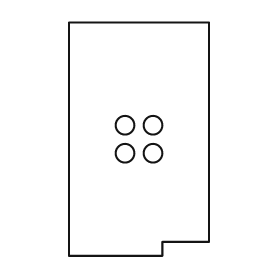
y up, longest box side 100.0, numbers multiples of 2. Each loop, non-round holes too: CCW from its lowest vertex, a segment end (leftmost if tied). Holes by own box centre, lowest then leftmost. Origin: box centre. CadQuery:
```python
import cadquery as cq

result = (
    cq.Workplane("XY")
    .moveTo(-30.0, -50.0)
    .lineTo(10.0, -50.0)
    .lineTo(10.0, -44.0)
    .lineTo(30.0, -44.0)
    .lineTo(30.0, 50.0)
    .lineTo(-30.0, 50.0)
    .close()
    .moveTo(-6.0, -6.0)
    .circle(4.0)
    .moveTo(6.0, -6.0)
    .circle(4.0)
    .moveTo(-6.0, 6.0)
    .circle(4.0)
    .moveTo(6.0, 6.0)
    .circle(4.0)
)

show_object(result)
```